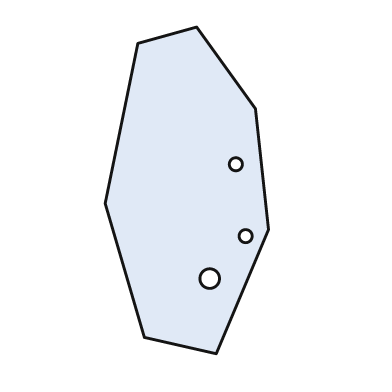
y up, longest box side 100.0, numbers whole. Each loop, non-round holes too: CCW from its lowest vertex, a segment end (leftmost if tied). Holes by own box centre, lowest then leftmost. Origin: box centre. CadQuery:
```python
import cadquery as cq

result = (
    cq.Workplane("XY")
    .moveTo(9.0, -50.0)
    .lineTo(25.0, -12.0)
    .lineTo(21.0, 25.0)
    .lineTo(3.0, 50.0)
    .lineTo(-15.0, 45.0)
    .lineTo(-25.0, -4.0)
    .lineTo(-13.0, -45.0)
    .close()
    .moveTo(7.0, -27.0)
    .circle(3.0)
    .moveTo(18.0, -14.0)
    .circle(2.0)
    .moveTo(15.0, 8.0)
    .circle(2.0)
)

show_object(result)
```